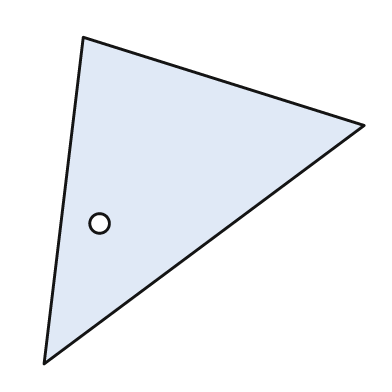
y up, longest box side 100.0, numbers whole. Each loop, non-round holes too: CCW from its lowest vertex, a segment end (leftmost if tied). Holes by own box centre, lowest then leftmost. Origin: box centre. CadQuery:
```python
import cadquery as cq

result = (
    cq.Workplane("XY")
    .moveTo(-49.0, -50.0)
    .lineTo(49.0, 23.0)
    .lineTo(-37.0, 50.0)
    .close()
    .moveTo(-32.0, -7.0)
    .circle(3.0)
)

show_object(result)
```